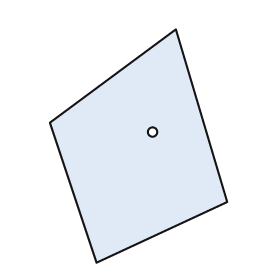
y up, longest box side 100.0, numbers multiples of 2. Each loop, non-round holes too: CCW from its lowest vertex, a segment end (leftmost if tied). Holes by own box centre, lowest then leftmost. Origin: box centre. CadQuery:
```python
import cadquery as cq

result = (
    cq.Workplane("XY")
    .moveTo(-18.0, -50.0)
    .lineTo(38.0, -24.0)
    .lineTo(16.0, 50.0)
    .lineTo(-38.0, 10.0)
    .close()
    .moveTo(6.0, 6.0)
    .circle(2.0)
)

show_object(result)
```